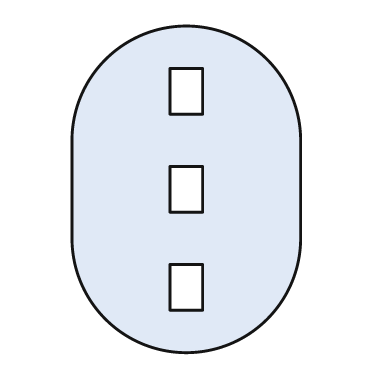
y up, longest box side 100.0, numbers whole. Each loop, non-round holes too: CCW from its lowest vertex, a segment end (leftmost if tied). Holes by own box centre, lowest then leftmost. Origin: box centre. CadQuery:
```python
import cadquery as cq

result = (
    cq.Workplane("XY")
    .moveTo(-35.0, -15.0)
    .threePointArc((0.0, -50.0), (35.0, -15.0))
    .lineTo(35.0, 15.0)
    .threePointArc((0.0, 50.0), (-35.0, 15.0))
    .close()
    .moveTo(-5.0, -37.0)
    .lineTo(5.0, -37.0)
    .lineTo(5.0, -23.0)
    .lineTo(-5.0, -23.0)
    .close()
    .moveTo(-5.0, -7.0)
    .lineTo(5.0, -7.0)
    .lineTo(5.0, 7.0)
    .lineTo(-5.0, 7.0)
    .close()
    .moveTo(-5.0, 23.0)
    .lineTo(5.0, 23.0)
    .lineTo(5.0, 37.0)
    .lineTo(-5.0, 37.0)
    .close()
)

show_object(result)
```